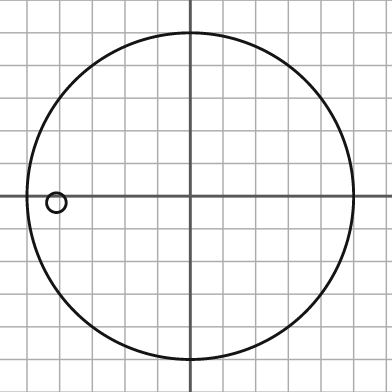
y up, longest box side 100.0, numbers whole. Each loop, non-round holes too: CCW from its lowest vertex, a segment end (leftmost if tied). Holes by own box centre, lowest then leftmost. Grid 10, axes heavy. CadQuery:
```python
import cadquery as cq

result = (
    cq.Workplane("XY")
    .moveTo(0.0, 0.0)
    .circle(50.0)
    .moveTo(-41.0, -2.0)
    .circle(3.0)
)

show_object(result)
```